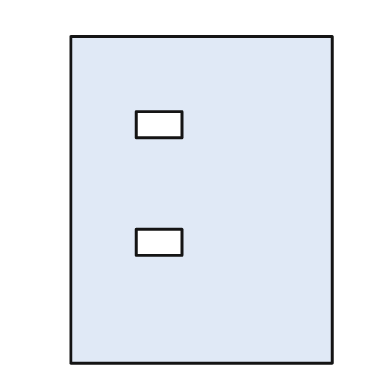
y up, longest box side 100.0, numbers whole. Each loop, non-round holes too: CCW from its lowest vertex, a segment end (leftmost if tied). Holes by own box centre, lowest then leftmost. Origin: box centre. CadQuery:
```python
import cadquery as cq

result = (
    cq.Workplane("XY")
    .moveTo(-40.0, -50.0)
    .lineTo(40.0, -50.0)
    .lineTo(40.0, 50.0)
    .lineTo(-40.0, 50.0)
    .close()
    .moveTo(-20.0, -17.0)
    .lineTo(-6.0, -17.0)
    .lineTo(-6.0, -9.0)
    .lineTo(-20.0, -9.0)
    .close()
    .moveTo(-20.0, 19.0)
    .lineTo(-6.0, 19.0)
    .lineTo(-6.0, 27.0)
    .lineTo(-20.0, 27.0)
    .close()
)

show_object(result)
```